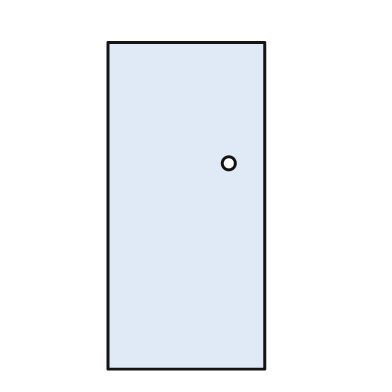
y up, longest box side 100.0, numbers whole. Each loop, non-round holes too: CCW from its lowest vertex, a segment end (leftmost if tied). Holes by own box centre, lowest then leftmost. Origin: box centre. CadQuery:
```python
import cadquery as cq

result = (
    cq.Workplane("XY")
    .moveTo(-24.0, -50.0)
    .lineTo(24.0, -50.0)
    .lineTo(24.0, 50.0)
    .lineTo(-24.0, 50.0)
    .close()
    .moveTo(13.0, 13.0)
    .circle(2.0)
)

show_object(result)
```